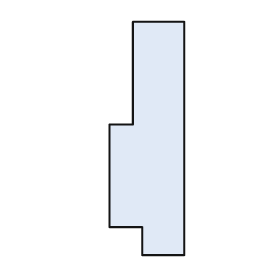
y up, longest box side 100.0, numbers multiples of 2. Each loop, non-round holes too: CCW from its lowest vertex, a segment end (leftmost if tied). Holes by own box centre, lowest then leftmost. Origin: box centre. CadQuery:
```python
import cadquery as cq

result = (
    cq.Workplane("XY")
    .moveTo(-2.0, -50.0)
    .lineTo(16.0, -50.0)
    .lineTo(16.0, 50.0)
    .lineTo(-6.0, 50.0)
    .lineTo(-6.0, 6.0)
    .lineTo(-16.0, 6.0)
    .lineTo(-16.0, -38.0)
    .lineTo(-2.0, -38.0)
    .close()
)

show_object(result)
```